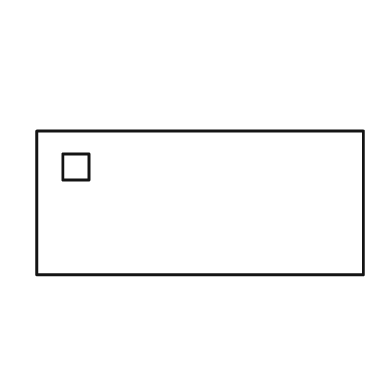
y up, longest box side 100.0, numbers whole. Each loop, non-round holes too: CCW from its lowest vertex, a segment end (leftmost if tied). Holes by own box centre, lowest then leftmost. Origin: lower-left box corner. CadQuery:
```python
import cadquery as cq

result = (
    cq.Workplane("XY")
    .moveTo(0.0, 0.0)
    .lineTo(100.0, 0.0)
    .lineTo(100.0, 44.0)
    .lineTo(0.0, 44.0)
    .close()
    .moveTo(8.0, 29.0)
    .lineTo(16.0, 29.0)
    .lineTo(16.0, 37.0)
    .lineTo(8.0, 37.0)
    .close()
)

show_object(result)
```